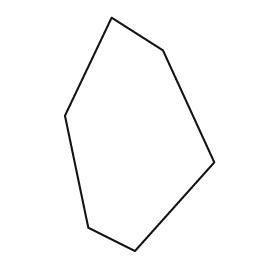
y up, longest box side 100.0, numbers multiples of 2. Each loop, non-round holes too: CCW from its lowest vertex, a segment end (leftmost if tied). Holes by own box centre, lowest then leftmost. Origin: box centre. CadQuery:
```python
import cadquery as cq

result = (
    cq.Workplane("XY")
    .moveTo(-2.0, -50.0)
    .lineTo(32.0, -12.0)
    .lineTo(10.0, 36.0)
    .lineTo(-12.0, 50.0)
    .lineTo(-32.0, 8.0)
    .lineTo(-22.0, -40.0)
    .close()
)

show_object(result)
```